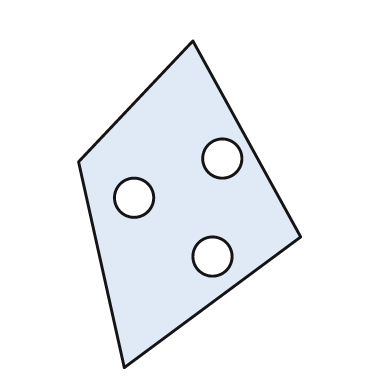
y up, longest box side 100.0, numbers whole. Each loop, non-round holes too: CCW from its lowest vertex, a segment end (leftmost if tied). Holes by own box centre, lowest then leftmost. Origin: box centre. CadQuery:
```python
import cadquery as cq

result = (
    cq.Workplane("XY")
    .moveTo(-20.0, -50.0)
    .lineTo(34.0, -10.0)
    .lineTo(1.0, 50.0)
    .lineTo(-34.0, 13.0)
    .close()
    .moveTo(7.0, -16.0)
    .circle(6.0)
    .moveTo(-17.0, 2.0)
    .circle(6.0)
    .moveTo(10.0, 14.0)
    .circle(6.0)
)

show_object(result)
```